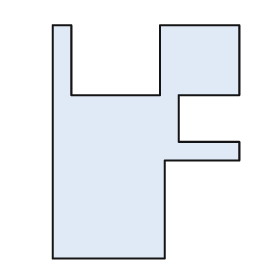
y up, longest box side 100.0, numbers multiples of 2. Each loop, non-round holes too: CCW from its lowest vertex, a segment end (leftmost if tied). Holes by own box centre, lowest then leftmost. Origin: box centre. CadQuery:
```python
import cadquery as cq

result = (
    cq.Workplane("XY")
    .moveTo(-40.0, -50.0)
    .lineTo(8.0, -50.0)
    .lineTo(8.0, -8.0)
    .lineTo(40.0, -8.0)
    .lineTo(40.0, 0.0)
    .lineTo(14.0, 0.0)
    .lineTo(14.0, 20.0)
    .lineTo(40.0, 20.0)
    .lineTo(40.0, 50.0)
    .lineTo(6.0, 50.0)
    .lineTo(6.0, 20.0)
    .lineTo(-32.0, 20.0)
    .lineTo(-32.0, 50.0)
    .lineTo(-40.0, 50.0)
    .close()
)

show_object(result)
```